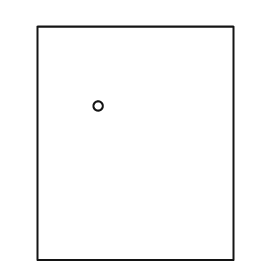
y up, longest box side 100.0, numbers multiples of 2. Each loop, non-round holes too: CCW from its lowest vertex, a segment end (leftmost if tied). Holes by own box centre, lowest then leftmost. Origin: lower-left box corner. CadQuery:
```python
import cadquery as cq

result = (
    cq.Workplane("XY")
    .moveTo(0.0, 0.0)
    .lineTo(84.0, 0.0)
    .lineTo(84.0, 100.0)
    .lineTo(0.0, 100.0)
    .close()
    .moveTo(26.0, 66.0)
    .circle(2.0)
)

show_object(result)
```